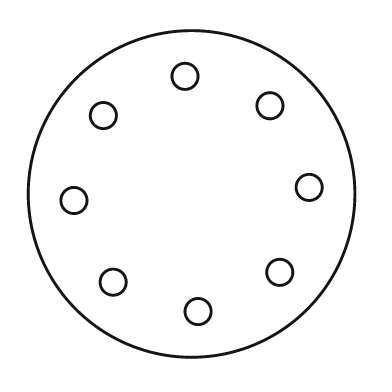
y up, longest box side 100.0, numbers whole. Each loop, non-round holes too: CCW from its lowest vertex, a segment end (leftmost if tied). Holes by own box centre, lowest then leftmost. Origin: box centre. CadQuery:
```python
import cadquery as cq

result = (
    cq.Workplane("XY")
    .moveTo(0.0, 0.0)
    .circle(50.0)
    .moveTo(2.0, -36.0)
    .circle(4.0)
    .moveTo(-24.0, -27.0)
    .circle(4.0)
    .moveTo(27.0, -24.0)
    .circle(4.0)
    .moveTo(-36.0, -2.0)
    .circle(4.0)
    .moveTo(36.0, 2.0)
    .circle(4.0)
    .moveTo(-27.0, 24.0)
    .circle(4.0)
    .moveTo(24.0, 27.0)
    .circle(4.0)
    .moveTo(-2.0, 36.0)
    .circle(4.0)
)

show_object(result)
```